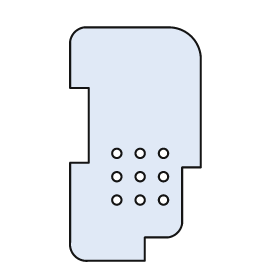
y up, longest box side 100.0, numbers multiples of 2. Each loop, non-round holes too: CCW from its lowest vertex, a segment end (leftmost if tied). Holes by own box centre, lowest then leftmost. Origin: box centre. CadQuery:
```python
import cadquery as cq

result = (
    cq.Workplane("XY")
    .moveTo(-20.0, -50.0)
    .lineTo(4.0, -50.0)
    .lineTo(4.0, -40.0)
    .lineTo(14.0, -40.0)
    .threePointArc((18.0, -38.0), (20.0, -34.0))
    .lineTo(20.0, -10.0)
    .lineTo(28.0, -10.0)
    .lineTo(28.0, 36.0)
    .threePointArc((24.0, 46.0), (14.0, 50.0))
    .lineTo(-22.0, 50.0)
    .threePointArc((-26.0, 48.0), (-28.0, 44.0))
    .lineTo(-28.0, 24.0)
    .lineTo(-20.0, 24.0)
    .lineTo(-20.0, -8.0)
    .lineTo(-28.0, -8.0)
    .lineTo(-28.0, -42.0)
    .threePointArc((-26.0, -48.0), (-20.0, -50.0))
    .close()
    .moveTo(-8.0, -24.0)
    .circle(2.0)
    .moveTo(2.0, -24.0)
    .circle(2.0)
    .moveTo(12.0, -24.0)
    .circle(2.0)
    .moveTo(-8.0, -14.0)
    .circle(2.0)
    .moveTo(2.0, -14.0)
    .circle(2.0)
    .moveTo(12.0, -14.0)
    .circle(2.0)
    .moveTo(-8.0, -4.0)
    .circle(2.0)
    .moveTo(2.0, -4.0)
    .circle(2.0)
    .moveTo(12.0, -4.0)
    .circle(2.0)
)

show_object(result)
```